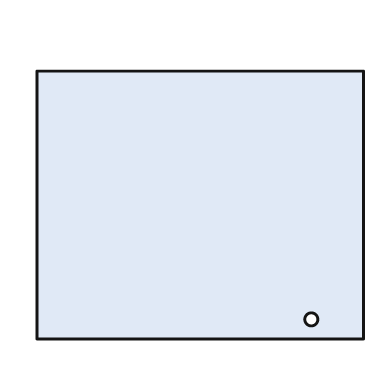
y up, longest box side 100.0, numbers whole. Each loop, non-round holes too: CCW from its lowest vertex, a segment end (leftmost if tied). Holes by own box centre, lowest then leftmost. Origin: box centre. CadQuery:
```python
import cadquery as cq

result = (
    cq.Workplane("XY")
    .moveTo(-50.0, -41.0)
    .lineTo(50.0, -41.0)
    .lineTo(50.0, 41.0)
    .lineTo(-50.0, 41.0)
    .close()
    .moveTo(34.0, -35.0)
    .circle(2.0)
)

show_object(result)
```